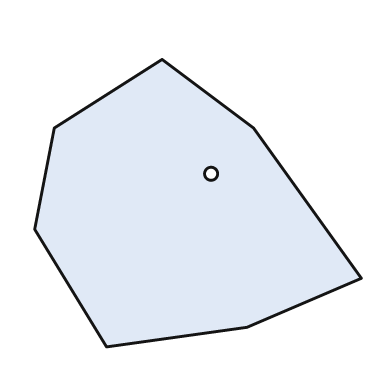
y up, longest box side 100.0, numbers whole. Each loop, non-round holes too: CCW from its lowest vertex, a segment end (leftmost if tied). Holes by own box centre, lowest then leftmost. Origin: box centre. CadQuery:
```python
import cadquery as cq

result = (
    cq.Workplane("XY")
    .moveTo(-28.0, -44.0)
    .lineTo(15.0, -38.0)
    .lineTo(50.0, -23.0)
    .lineTo(17.0, 23.0)
    .lineTo(-11.0, 44.0)
    .lineTo(-44.0, 23.0)
    .lineTo(-50.0, -8.0)
    .close()
    .moveTo(4.0, 9.0)
    .circle(2.0)
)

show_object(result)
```